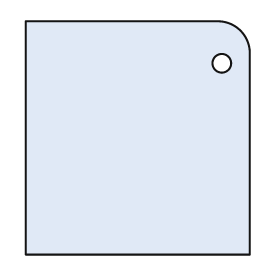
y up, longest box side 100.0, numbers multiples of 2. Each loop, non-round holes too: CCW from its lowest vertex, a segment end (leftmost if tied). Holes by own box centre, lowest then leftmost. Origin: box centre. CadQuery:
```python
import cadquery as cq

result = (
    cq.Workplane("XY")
    .moveTo(-48.0, -50.0)
    .lineTo(48.0, -50.0)
    .lineTo(48.0, 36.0)
    .threePointArc((44.0, 46.0), (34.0, 50.0))
    .lineTo(-48.0, 50.0)
    .close()
    .moveTo(36.0, 32.0)
    .circle(4.0)
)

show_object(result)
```